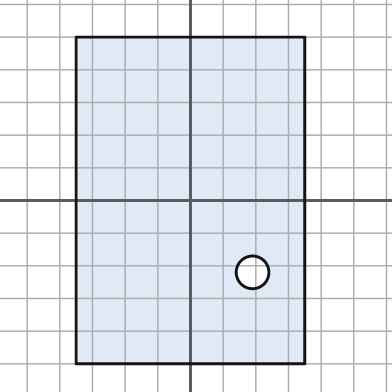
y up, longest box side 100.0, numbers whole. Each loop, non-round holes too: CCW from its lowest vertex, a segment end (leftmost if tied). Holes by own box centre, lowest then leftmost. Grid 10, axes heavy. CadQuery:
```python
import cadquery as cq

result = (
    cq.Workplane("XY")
    .moveTo(-35.0, -50.0)
    .lineTo(35.0, -50.0)
    .lineTo(35.0, 50.0)
    .lineTo(-35.0, 50.0)
    .close()
    .moveTo(19.0, -22.0)
    .circle(5.0)
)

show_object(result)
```